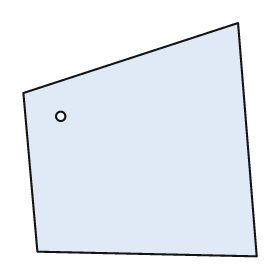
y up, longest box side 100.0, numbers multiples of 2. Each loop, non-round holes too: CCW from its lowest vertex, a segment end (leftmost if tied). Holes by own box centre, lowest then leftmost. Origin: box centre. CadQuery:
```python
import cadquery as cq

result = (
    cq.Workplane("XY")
    .moveTo(50.0, -50.0)
    .lineTo(42.0, 50.0)
    .lineTo(-50.0, 20.0)
    .lineTo(-44.0, -48.0)
    .close()
    .moveTo(-34.0, 10.0)
    .circle(2.0)
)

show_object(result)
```